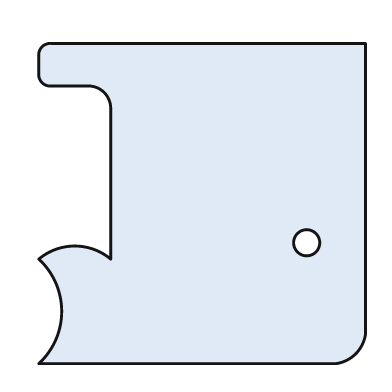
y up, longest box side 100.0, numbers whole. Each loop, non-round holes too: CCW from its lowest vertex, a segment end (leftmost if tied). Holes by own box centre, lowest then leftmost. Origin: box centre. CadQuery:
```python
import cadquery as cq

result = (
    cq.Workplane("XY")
    .moveTo(-50.0, -49.0)
    .lineTo(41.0, -49.0)
    .threePointArc((47.0, -46.0), (50.0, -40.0))
    .lineTo(50.0, 49.0)
    .lineTo(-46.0, 49.0)
    .threePointArc((-49.0, 48.0), (-50.0, 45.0))
    .lineTo(-50.0, 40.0)
    .threePointArc((-49.0, 37.0), (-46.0, 36.0))
    .lineTo(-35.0, 36.0)
    .threePointArc((-30.0, 34.0), (-28.0, 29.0))
    .lineTo(-28.0, -17.0)
    .threePointArc((-39.0, -13.0), (-50.0, -17.0))
    .threePointArc((-43.0, -33.0), (-50.0, -49.0))
    .close()
    .moveTo(32.0, -12.0)
    .circle(4.0)
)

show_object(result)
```